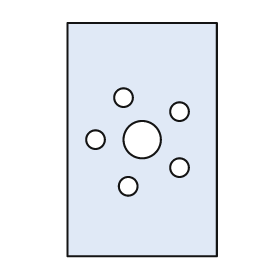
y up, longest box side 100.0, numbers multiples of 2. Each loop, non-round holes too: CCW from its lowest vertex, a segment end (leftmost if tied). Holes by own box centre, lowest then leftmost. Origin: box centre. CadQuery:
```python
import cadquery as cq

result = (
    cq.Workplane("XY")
    .moveTo(-32.0, -50.0)
    .lineTo(32.0, -50.0)
    .lineTo(32.0, 50.0)
    .lineTo(-32.0, 50.0)
    .close()
    .moveTo(-6.0, -20.0)
    .circle(4.0)
    .moveTo(16.0, -12.0)
    .circle(4.0)
    .moveTo(-20.0, 0.0)
    .circle(4.0)
    .moveTo(0.0, 0.0)
    .circle(8.0)
    .moveTo(16.0, 12.0)
    .circle(4.0)
    .moveTo(-8.0, 18.0)
    .circle(4.0)
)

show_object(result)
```